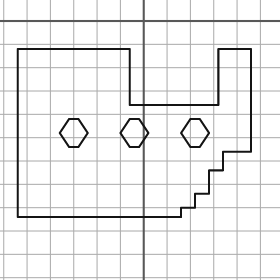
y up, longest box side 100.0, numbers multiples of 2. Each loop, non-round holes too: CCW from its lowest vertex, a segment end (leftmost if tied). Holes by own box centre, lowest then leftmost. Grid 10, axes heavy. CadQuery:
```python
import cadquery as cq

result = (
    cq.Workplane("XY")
    .moveTo(-54.0, -84.0)
    .lineTo(16.0, -84.0)
    .lineTo(16.0, -80.0)
    .lineTo(22.0, -80.0)
    .lineTo(22.0, -74.0)
    .lineTo(28.0, -74.0)
    .lineTo(28.0, -64.0)
    .lineTo(34.0, -64.0)
    .lineTo(34.0, -56.0)
    .lineTo(46.0, -56.0)
    .lineTo(46.0, -12.0)
    .lineTo(32.0, -12.0)
    .lineTo(32.0, -36.0)
    .lineTo(-6.0, -36.0)
    .lineTo(-6.0, -12.0)
    .lineTo(-54.0, -12.0)
    .close()
    .moveTo(-32.0, -54.0)
    .lineTo(-28.0, -54.0)
    .lineTo(-24.0, -48.0)
    .lineTo(-28.0, -42.0)
    .lineTo(-32.0, -42.0)
    .lineTo(-36.0, -48.0)
    .close()
    .moveTo(-6.0, -54.0)
    .lineTo(-2.0, -54.0)
    .lineTo(2.0, -48.0)
    .lineTo(-2.0, -42.0)
    .lineTo(-6.0, -42.0)
    .lineTo(-10.0, -48.0)
    .close()
    .moveTo(20.0, -54.0)
    .lineTo(24.0, -54.0)
    .lineTo(28.0, -48.0)
    .lineTo(24.0, -42.0)
    .lineTo(20.0, -42.0)
    .lineTo(16.0, -48.0)
    .close()
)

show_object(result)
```